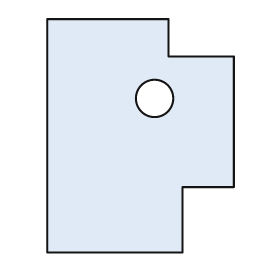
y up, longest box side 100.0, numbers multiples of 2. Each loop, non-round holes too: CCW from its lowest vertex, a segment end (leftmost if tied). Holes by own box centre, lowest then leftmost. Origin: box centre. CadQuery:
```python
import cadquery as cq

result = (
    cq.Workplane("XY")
    .moveTo(-40.0, -50.0)
    .lineTo(18.0, -50.0)
    .lineTo(18.0, -22.0)
    .lineTo(40.0, -22.0)
    .lineTo(40.0, 34.0)
    .lineTo(12.0, 34.0)
    .lineTo(12.0, 50.0)
    .lineTo(-40.0, 50.0)
    .close()
    .moveTo(6.0, 16.0)
    .circle(8.0)
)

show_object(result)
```